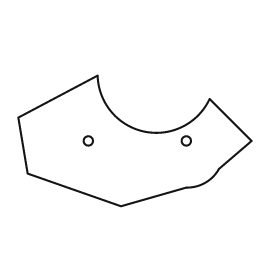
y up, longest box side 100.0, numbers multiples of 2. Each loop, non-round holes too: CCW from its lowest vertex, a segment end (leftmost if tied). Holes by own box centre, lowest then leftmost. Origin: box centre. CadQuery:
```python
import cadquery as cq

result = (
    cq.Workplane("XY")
    .moveTo(-6.0, -28.0)
    .lineTo(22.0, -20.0)
    .threePointArc((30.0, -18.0), (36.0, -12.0))
    .lineTo(50.0, 0.0)
    .lineTo(32.0, 18.0)
    .threePointArc((4.0, 4.0), (-16.0, 28.0))
    .lineTo(-50.0, 10.0)
    .lineTo(-46.0, -14.0)
    .close()
    .moveTo(-20.0, 0.0)
    .circle(2.0)
    .moveTo(22.0, 0.0)
    .circle(2.0)
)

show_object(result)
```